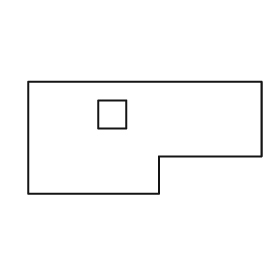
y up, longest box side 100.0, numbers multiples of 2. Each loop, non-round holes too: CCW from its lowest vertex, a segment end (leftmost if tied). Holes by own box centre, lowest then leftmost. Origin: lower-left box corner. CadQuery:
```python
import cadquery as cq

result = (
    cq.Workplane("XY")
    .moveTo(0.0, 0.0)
    .lineTo(56.0, 0.0)
    .lineTo(56.0, 16.0)
    .lineTo(100.0, 16.0)
    .lineTo(100.0, 48.0)
    .lineTo(0.0, 48.0)
    .close()
    .moveTo(30.0, 28.0)
    .lineTo(42.0, 28.0)
    .lineTo(42.0, 40.0)
    .lineTo(30.0, 40.0)
    .close()
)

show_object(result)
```